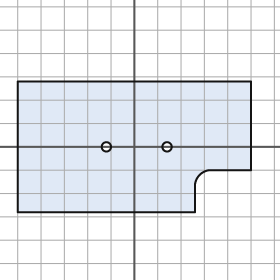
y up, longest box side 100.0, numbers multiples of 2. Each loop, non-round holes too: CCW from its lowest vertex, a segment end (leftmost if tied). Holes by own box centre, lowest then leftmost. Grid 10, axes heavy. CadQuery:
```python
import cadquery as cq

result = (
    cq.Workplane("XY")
    .moveTo(-50.0, -28.0)
    .lineTo(26.0, -28.0)
    .lineTo(26.0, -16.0)
    .threePointArc((28.0, -12.0), (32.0, -10.0))
    .lineTo(50.0, -10.0)
    .lineTo(50.0, 28.0)
    .lineTo(-50.0, 28.0)
    .close()
    .moveTo(-12.0, 0.0)
    .circle(2.0)
    .moveTo(14.0, 0.0)
    .circle(2.0)
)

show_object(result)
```